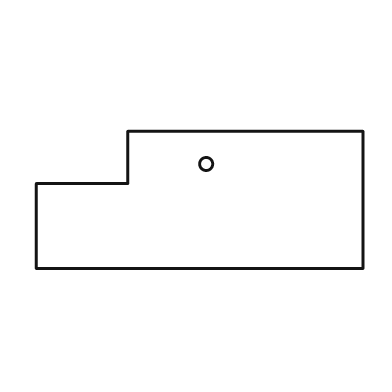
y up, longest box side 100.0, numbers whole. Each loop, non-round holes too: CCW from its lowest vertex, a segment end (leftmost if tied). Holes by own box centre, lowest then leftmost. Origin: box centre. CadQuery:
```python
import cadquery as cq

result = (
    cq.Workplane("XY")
    .moveTo(-50.0, -21.0)
    .lineTo(50.0, -21.0)
    .lineTo(50.0, 21.0)
    .lineTo(-22.0, 21.0)
    .lineTo(-22.0, 5.0)
    .lineTo(-50.0, 5.0)
    .close()
    .moveTo(2.0, 11.0)
    .circle(2.0)
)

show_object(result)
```